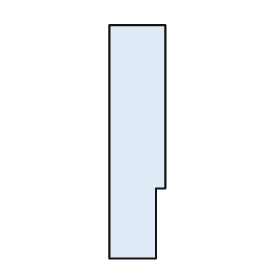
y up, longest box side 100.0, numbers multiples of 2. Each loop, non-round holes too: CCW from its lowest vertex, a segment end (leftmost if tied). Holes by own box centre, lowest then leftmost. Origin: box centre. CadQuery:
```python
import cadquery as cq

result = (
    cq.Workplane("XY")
    .moveTo(-12.0, -50.0)
    .lineTo(8.0, -50.0)
    .lineTo(8.0, -20.0)
    .lineTo(12.0, -20.0)
    .lineTo(12.0, 50.0)
    .lineTo(-12.0, 50.0)
    .close()
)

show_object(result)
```